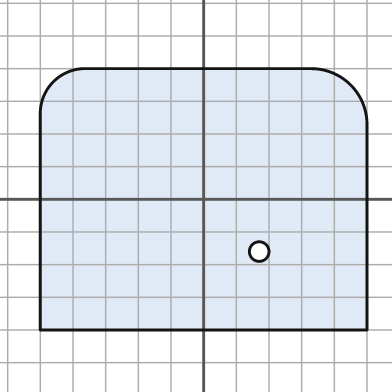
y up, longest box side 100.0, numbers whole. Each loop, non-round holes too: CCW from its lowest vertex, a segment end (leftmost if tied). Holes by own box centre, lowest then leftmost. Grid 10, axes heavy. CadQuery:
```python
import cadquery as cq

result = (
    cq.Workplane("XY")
    .moveTo(-50.0, -40.0)
    .lineTo(50.0, -40.0)
    .lineTo(50.0, 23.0)
    .threePointArc((45.0, 35.0), (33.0, 40.0))
    .lineTo(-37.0, 40.0)
    .threePointArc((-46.0, 36.0), (-50.0, 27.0))
    .close()
    .moveTo(17.0, -16.0)
    .circle(3.0)
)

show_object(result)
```